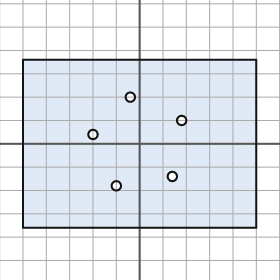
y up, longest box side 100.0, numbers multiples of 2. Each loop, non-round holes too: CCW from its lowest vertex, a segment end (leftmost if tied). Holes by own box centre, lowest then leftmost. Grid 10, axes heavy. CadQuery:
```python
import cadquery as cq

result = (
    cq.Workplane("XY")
    .moveTo(-50.0, -36.0)
    .lineTo(50.0, -36.0)
    .lineTo(50.0, 36.0)
    .lineTo(-50.0, 36.0)
    .close()
    .moveTo(-10.0, -18.0)
    .circle(2.0)
    .moveTo(14.0, -14.0)
    .circle(2.0)
    .moveTo(-20.0, 4.0)
    .circle(2.0)
    .moveTo(18.0, 10.0)
    .circle(2.0)
    .moveTo(-4.0, 20.0)
    .circle(2.0)
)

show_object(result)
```